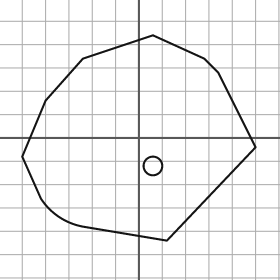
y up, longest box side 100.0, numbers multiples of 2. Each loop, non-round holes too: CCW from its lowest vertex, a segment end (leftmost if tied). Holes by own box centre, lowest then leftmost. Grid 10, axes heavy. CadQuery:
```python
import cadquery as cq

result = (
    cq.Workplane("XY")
    .moveTo(12.0, -44.0)
    .lineTo(50.0, -4.0)
    .lineTo(34.0, 28.0)
    .lineTo(28.0, 34.0)
    .lineTo(6.0, 44.0)
    .lineTo(-24.0, 34.0)
    .lineTo(-40.0, 16.0)
    .lineTo(-50.0, -8.0)
    .lineTo(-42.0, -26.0)
    .threePointArc((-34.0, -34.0), (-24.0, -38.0))
    .close()
    .moveTo(6.0, -12.0)
    .circle(4.0)
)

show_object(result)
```